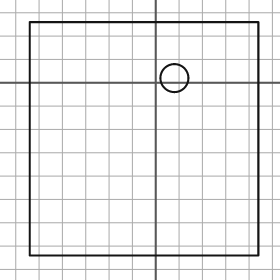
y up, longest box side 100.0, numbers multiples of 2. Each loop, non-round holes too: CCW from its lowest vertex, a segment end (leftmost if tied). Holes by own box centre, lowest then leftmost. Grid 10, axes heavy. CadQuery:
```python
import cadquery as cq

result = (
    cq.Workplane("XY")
    .moveTo(-54.0, -74.0)
    .lineTo(44.0, -74.0)
    .lineTo(44.0, 26.0)
    .lineTo(-54.0, 26.0)
    .close()
    .moveTo(8.0, 2.0)
    .circle(6.0)
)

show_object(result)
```